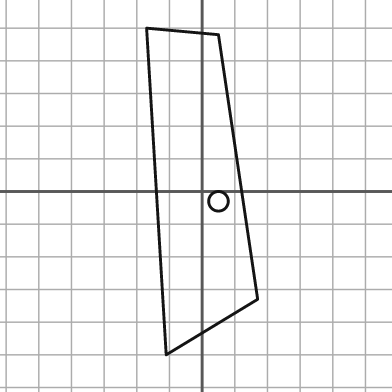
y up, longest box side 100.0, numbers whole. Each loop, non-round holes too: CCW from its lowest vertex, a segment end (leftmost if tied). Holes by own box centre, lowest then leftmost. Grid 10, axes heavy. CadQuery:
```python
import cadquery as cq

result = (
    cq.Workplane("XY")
    .moveTo(-11.0, -50.0)
    .lineTo(17.0, -33.0)
    .lineTo(5.0, 48.0)
    .lineTo(-17.0, 50.0)
    .close()
    .moveTo(5.0, -3.0)
    .circle(3.0)
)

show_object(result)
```